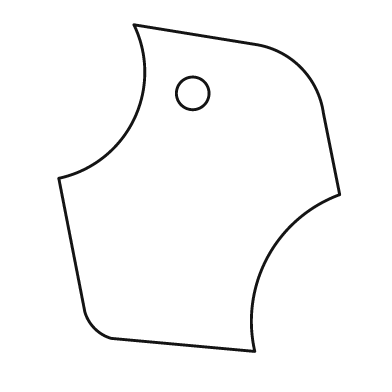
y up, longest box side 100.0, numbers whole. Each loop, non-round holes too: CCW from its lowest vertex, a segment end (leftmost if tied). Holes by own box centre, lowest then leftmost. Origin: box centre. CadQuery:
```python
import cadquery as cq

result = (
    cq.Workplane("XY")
    .moveTo(17.0, -50.0)
    .threePointArc((21.0, -21.0), (43.0, -2.0))
    .lineTo(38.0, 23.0)
    .threePointArc((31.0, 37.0), (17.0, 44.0))
    .lineTo(-20.0, 50.0)
    .threePointArc((-20.0, 21.0), (-43.0, 3.0))
    .lineTo(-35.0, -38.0)
    .threePointArc((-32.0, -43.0), (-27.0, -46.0))
    .close()
    .moveTo(-2.0, 29.0)
    .circle(5.0)
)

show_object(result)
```